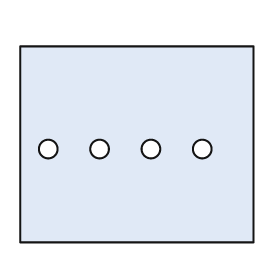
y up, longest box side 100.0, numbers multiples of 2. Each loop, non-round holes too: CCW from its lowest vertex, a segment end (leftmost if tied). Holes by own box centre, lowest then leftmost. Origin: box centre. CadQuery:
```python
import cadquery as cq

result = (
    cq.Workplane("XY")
    .moveTo(-50.0, -42.0)
    .lineTo(50.0, -42.0)
    .lineTo(50.0, 42.0)
    .lineTo(-50.0, 42.0)
    .close()
    .moveTo(-38.0, -2.0)
    .circle(4.0)
    .moveTo(-16.0, -2.0)
    .circle(4.0)
    .moveTo(6.0, -2.0)
    .circle(4.0)
    .moveTo(28.0, -2.0)
    .circle(4.0)
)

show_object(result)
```